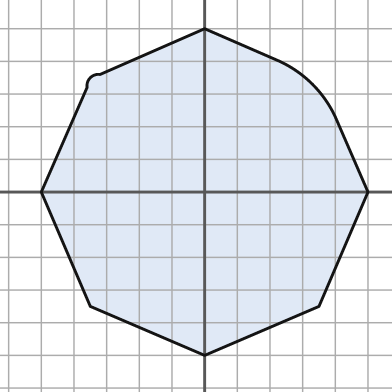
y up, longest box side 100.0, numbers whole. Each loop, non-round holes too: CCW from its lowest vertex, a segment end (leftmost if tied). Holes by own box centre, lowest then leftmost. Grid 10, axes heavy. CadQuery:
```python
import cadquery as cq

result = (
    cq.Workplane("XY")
    .moveTo(0.0, -50.0)
    .lineTo(35.0, -35.0)
    .lineTo(50.0, 0.0)
    .lineTo(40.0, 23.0)
    .threePointArc((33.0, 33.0), (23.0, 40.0))
    .lineTo(0.0, 50.0)
    .lineTo(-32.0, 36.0)
    .threePointArc((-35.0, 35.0), (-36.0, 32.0))
    .lineTo(-50.0, 0.0)
    .lineTo(-35.0, -35.0)
    .close()
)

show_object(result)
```